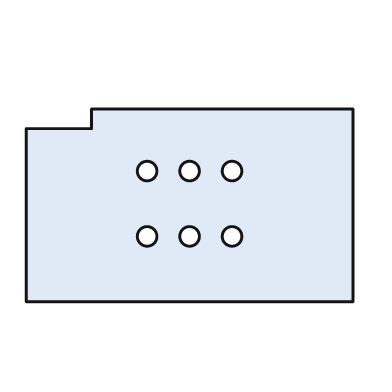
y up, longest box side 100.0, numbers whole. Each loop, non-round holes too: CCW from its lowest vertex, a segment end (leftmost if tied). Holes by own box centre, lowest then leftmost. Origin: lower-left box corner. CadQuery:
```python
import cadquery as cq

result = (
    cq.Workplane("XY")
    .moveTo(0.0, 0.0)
    .lineTo(100.0, 0.0)
    .lineTo(100.0, 59.0)
    .lineTo(20.0, 59.0)
    .lineTo(20.0, 53.0)
    .lineTo(0.0, 53.0)
    .close()
    .moveTo(37.0, 20.0)
    .circle(3.0)
    .moveTo(50.0, 20.0)
    .circle(3.0)
    .moveTo(63.0, 20.0)
    .circle(3.0)
    .moveTo(37.0, 40.0)
    .circle(3.0)
    .moveTo(50.0, 40.0)
    .circle(3.0)
    .moveTo(63.0, 40.0)
    .circle(3.0)
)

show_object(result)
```